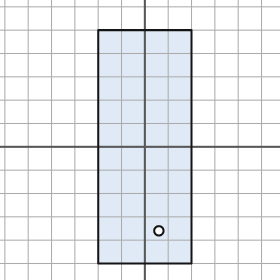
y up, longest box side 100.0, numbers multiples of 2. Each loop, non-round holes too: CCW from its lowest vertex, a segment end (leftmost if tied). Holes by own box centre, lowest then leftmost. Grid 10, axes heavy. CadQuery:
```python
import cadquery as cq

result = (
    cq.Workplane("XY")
    .moveTo(-20.0, -50.0)
    .lineTo(20.0, -50.0)
    .lineTo(20.0, 50.0)
    .lineTo(-20.0, 50.0)
    .close()
    .moveTo(6.0, -36.0)
    .circle(2.0)
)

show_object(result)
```